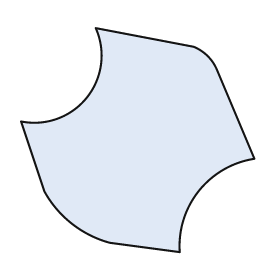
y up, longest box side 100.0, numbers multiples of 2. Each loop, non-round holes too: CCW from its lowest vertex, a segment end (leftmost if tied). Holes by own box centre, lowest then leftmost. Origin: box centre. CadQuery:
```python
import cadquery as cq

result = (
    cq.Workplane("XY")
    .moveTo(18.0, -48.0)
    .threePointArc((26.0, -22.0), (50.0, -8.0))
    .lineTo(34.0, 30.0)
    .threePointArc((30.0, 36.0), (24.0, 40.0))
    .lineTo(-18.0, 48.0)
    .threePointArc((-22.0, 18.0), (-50.0, 8.0))
    .lineTo(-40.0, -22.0)
    .threePointArc((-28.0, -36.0), (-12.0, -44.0))
    .close()
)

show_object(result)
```